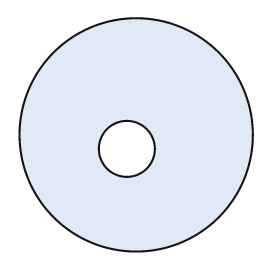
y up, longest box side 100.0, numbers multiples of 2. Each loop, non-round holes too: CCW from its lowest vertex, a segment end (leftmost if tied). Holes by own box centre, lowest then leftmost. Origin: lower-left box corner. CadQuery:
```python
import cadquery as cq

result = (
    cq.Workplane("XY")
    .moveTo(50.0, 50.0)
    .circle(50.0)
    .moveTo(46.0, 44.0)
    .circle(12.0)
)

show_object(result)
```